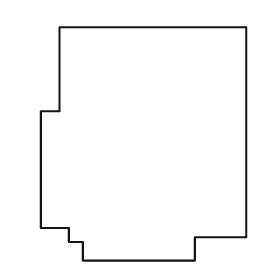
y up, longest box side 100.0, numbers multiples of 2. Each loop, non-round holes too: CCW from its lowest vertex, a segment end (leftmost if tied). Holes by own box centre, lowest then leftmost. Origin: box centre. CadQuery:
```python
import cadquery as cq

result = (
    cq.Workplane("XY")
    .moveTo(-26.0, -50.0)
    .lineTo(22.0, -50.0)
    .lineTo(22.0, -40.0)
    .lineTo(44.0, -40.0)
    .lineTo(44.0, 50.0)
    .lineTo(-36.0, 50.0)
    .lineTo(-36.0, 14.0)
    .lineTo(-44.0, 14.0)
    .lineTo(-44.0, -36.0)
    .lineTo(-32.0, -36.0)
    .lineTo(-32.0, -42.0)
    .lineTo(-26.0, -42.0)
    .close()
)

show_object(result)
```